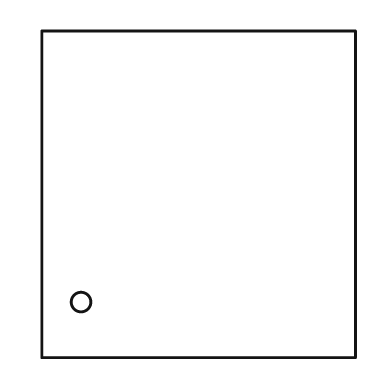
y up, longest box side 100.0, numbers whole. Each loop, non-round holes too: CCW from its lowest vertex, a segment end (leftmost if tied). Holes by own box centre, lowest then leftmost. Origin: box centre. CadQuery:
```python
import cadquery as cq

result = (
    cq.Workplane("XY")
    .moveTo(-48.0, -50.0)
    .lineTo(48.0, -50.0)
    .lineTo(48.0, 50.0)
    .lineTo(-48.0, 50.0)
    .close()
    .moveTo(-36.0, -33.0)
    .circle(3.0)
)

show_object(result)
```